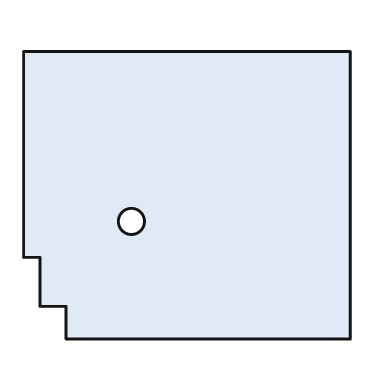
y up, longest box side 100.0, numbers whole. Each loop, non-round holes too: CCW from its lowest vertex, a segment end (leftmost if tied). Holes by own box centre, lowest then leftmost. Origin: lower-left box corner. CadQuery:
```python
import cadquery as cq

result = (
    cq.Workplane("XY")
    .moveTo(13.0, 0.0)
    .lineTo(100.0, 0.0)
    .lineTo(100.0, 88.0)
    .lineTo(0.0, 88.0)
    .lineTo(0.0, 25.0)
    .lineTo(5.0, 25.0)
    .lineTo(5.0, 10.0)
    .lineTo(13.0, 10.0)
    .close()
    .moveTo(33.0, 36.0)
    .circle(4.0)
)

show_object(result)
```